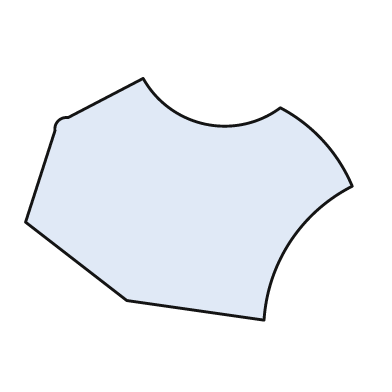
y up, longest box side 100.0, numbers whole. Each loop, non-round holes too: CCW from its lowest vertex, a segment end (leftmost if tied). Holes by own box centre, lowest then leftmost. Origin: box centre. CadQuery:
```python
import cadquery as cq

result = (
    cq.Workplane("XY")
    .moveTo(23.0, -37.0)
    .threePointArc((31.0, -13.0), (50.0, 4.0))
    .threePointArc((41.0, 18.0), (28.0, 28.0))
    .threePointArc((5.0, 23.0), (-14.0, 37.0))
    .lineTo(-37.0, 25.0)
    .threePointArc((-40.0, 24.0), (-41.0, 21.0))
    .lineTo(-50.0, -7.0)
    .lineTo(-19.0, -31.0)
    .close()
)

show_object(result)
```